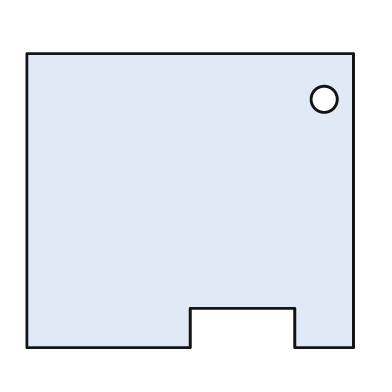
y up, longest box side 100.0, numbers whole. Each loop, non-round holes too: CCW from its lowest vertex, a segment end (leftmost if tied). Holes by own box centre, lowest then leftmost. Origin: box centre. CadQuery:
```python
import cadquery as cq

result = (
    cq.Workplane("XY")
    .moveTo(-50.0, -45.0)
    .lineTo(0.0, -45.0)
    .lineTo(0.0, -33.0)
    .lineTo(32.0, -33.0)
    .lineTo(32.0, -45.0)
    .lineTo(50.0, -45.0)
    .lineTo(50.0, 45.0)
    .lineTo(-50.0, 45.0)
    .close()
    .moveTo(41.0, 31.0)
    .circle(4.0)
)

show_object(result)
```